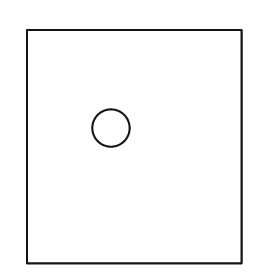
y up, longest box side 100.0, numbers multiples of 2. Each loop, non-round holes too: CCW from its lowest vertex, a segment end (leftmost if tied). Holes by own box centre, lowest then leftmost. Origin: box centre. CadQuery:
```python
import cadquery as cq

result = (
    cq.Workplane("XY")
    .moveTo(-46.0, -50.0)
    .lineTo(46.0, -50.0)
    .lineTo(46.0, 50.0)
    .lineTo(-46.0, 50.0)
    .close()
    .moveTo(-10.0, 8.0)
    .circle(8.0)
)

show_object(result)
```